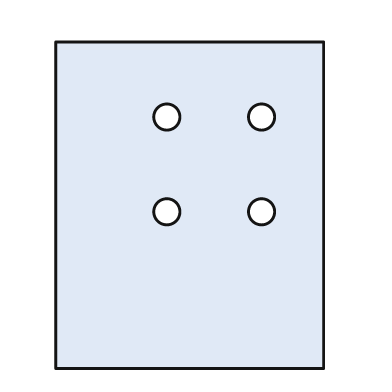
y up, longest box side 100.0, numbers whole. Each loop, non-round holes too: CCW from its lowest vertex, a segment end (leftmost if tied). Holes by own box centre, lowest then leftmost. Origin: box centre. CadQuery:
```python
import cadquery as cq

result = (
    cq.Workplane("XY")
    .moveTo(-41.0, -50.0)
    .lineTo(41.0, -50.0)
    .lineTo(41.0, 50.0)
    .lineTo(-41.0, 50.0)
    .close()
    .moveTo(-7.0, -2.0)
    .circle(4.0)
    .moveTo(22.0, -2.0)
    .circle(4.0)
    .moveTo(-7.0, 27.0)
    .circle(4.0)
    .moveTo(22.0, 27.0)
    .circle(4.0)
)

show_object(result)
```